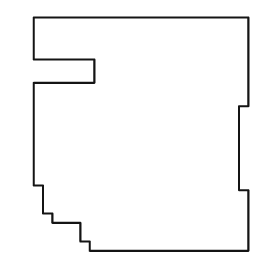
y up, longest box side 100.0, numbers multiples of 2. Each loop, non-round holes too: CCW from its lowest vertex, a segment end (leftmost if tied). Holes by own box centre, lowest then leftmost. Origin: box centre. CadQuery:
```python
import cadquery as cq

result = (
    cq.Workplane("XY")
    .moveTo(-22.0, -50.0)
    .lineTo(46.0, -50.0)
    .lineTo(46.0, -24.0)
    .lineTo(42.0, -24.0)
    .lineTo(42.0, 12.0)
    .lineTo(46.0, 12.0)
    .lineTo(46.0, 50.0)
    .lineTo(-46.0, 50.0)
    .lineTo(-46.0, 32.0)
    .lineTo(-20.0, 32.0)
    .lineTo(-20.0, 22.0)
    .lineTo(-46.0, 22.0)
    .lineTo(-46.0, -22.0)
    .lineTo(-42.0, -22.0)
    .lineTo(-42.0, -34.0)
    .lineTo(-38.0, -34.0)
    .lineTo(-38.0, -38.0)
    .lineTo(-26.0, -38.0)
    .lineTo(-26.0, -46.0)
    .lineTo(-22.0, -46.0)
    .close()
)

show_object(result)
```